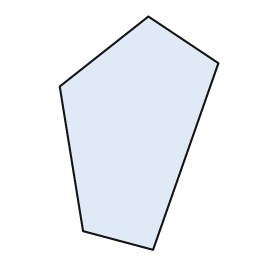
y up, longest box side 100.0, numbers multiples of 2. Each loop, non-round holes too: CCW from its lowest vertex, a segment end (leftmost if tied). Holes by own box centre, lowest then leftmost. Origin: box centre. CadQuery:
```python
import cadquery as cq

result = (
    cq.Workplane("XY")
    .moveTo(6.0, -50.0)
    .lineTo(34.0, 30.0)
    .lineTo(4.0, 50.0)
    .lineTo(-34.0, 20.0)
    .lineTo(-24.0, -42.0)
    .close()
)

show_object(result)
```